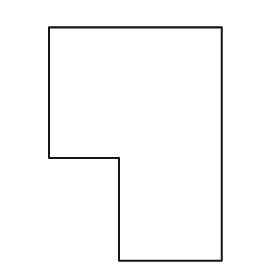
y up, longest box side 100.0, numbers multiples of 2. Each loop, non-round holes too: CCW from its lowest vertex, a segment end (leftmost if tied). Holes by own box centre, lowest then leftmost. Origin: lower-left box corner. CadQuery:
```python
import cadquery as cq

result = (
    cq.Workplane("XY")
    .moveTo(30.0, 0.0)
    .lineTo(74.0, 0.0)
    .lineTo(74.0, 100.0)
    .lineTo(0.0, 100.0)
    .lineTo(0.0, 44.0)
    .lineTo(30.0, 44.0)
    .close()
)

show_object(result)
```